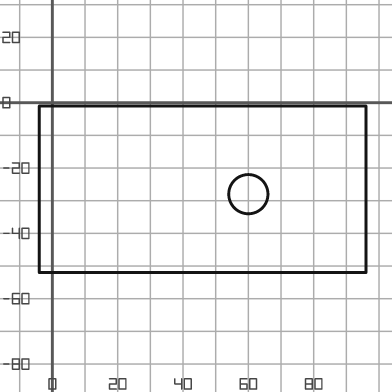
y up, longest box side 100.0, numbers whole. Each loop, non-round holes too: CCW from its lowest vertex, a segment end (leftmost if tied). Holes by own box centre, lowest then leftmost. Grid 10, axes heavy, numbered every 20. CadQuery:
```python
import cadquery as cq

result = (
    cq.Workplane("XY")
    .moveTo(-4.0, -52.0)
    .lineTo(96.0, -52.0)
    .lineTo(96.0, -1.0)
    .lineTo(-4.0, -1.0)
    .close()
    .moveTo(60.0, -28.0)
    .circle(6.0)
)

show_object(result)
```